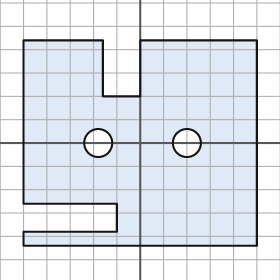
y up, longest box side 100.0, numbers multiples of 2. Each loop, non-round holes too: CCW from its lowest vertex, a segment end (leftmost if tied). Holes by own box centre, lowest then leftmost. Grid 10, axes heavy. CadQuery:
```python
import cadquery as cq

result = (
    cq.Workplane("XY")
    .moveTo(-50.0, -44.0)
    .lineTo(50.0, -44.0)
    .lineTo(50.0, 44.0)
    .lineTo(0.0, 44.0)
    .lineTo(0.0, 20.0)
    .lineTo(-16.0, 20.0)
    .lineTo(-16.0, 44.0)
    .lineTo(-50.0, 44.0)
    .lineTo(-50.0, -26.0)
    .lineTo(-10.0, -26.0)
    .lineTo(-10.0, -38.0)
    .lineTo(-50.0, -38.0)
    .close()
    .moveTo(-18.0, 0.0)
    .circle(6.0)
    .moveTo(20.0, 0.0)
    .circle(6.0)
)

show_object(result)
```